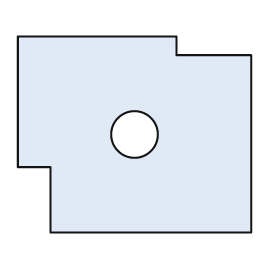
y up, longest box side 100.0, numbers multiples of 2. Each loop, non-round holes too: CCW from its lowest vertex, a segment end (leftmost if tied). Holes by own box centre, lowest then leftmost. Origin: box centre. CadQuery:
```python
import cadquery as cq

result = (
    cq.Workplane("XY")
    .moveTo(-36.0, -42.0)
    .lineTo(50.0, -42.0)
    .lineTo(50.0, 34.0)
    .lineTo(18.0, 34.0)
    .lineTo(18.0, 42.0)
    .lineTo(-50.0, 42.0)
    .lineTo(-50.0, -14.0)
    .lineTo(-36.0, -14.0)
    .close()
    .moveTo(0.0, 0.0)
    .circle(10.0)
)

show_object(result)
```